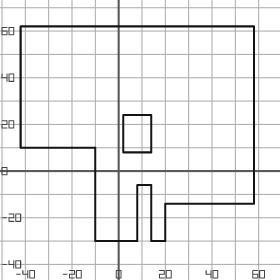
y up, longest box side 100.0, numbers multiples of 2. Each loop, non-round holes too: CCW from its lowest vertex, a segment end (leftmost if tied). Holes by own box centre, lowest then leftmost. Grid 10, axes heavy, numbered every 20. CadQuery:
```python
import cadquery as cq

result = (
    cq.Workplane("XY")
    .moveTo(-10.0, -30.0)
    .lineTo(8.0, -30.0)
    .lineTo(8.0, -6.0)
    .lineTo(14.0, -6.0)
    .lineTo(14.0, -30.0)
    .lineTo(20.0, -30.0)
    .lineTo(20.0, -14.0)
    .lineTo(58.0, -14.0)
    .lineTo(58.0, 62.0)
    .lineTo(-42.0, 62.0)
    .lineTo(-42.0, 10.0)
    .lineTo(-10.0, 10.0)
    .close()
    .moveTo(2.0, 8.0)
    .lineTo(14.0, 8.0)
    .lineTo(14.0, 24.0)
    .lineTo(2.0, 24.0)
    .close()
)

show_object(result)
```